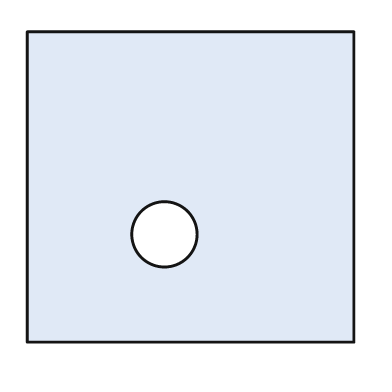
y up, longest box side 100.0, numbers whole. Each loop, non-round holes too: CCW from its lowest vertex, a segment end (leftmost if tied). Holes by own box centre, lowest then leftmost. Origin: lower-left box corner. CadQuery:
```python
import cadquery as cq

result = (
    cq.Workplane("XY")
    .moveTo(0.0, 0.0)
    .lineTo(100.0, 0.0)
    .lineTo(100.0, 95.0)
    .lineTo(0.0, 95.0)
    .close()
    .moveTo(42.0, 33.0)
    .circle(10.0)
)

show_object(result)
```